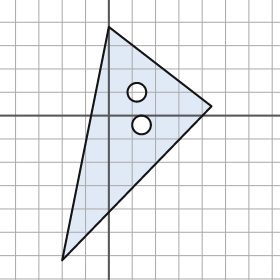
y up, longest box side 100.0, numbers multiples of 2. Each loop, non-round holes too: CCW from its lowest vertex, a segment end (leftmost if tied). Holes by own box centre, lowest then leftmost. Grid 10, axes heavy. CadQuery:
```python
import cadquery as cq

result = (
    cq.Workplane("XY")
    .moveTo(-20.0, -62.0)
    .lineTo(44.0, 4.0)
    .lineTo(0.0, 38.0)
    .close()
    .moveTo(14.0, -4.0)
    .circle(4.0)
    .moveTo(12.0, 10.0)
    .circle(4.0)
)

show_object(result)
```